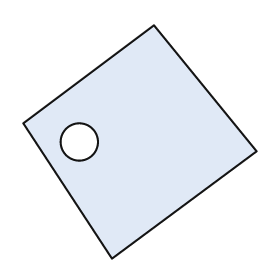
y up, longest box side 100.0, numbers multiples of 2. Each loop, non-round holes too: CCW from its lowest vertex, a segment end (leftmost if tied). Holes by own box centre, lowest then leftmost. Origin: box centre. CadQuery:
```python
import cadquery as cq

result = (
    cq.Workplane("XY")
    .moveTo(-12.0, -50.0)
    .lineTo(50.0, -4.0)
    .lineTo(6.0, 50.0)
    .lineTo(-50.0, 8.0)
    .close()
    .moveTo(-26.0, 0.0)
    .circle(8.0)
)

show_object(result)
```